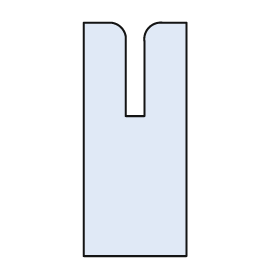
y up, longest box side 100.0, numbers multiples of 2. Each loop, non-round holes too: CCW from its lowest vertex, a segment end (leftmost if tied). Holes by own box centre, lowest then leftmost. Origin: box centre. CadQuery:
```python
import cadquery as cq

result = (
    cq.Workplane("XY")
    .moveTo(-22.0, -50.0)
    .lineTo(22.0, -50.0)
    .lineTo(22.0, 50.0)
    .lineTo(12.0, 50.0)
    .threePointArc((6.0, 48.0), (4.0, 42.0))
    .lineTo(4.0, 10.0)
    .lineTo(-4.0, 10.0)
    .lineTo(-4.0, 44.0)
    .threePointArc((-6.0, 48.0), (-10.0, 50.0))
    .lineTo(-22.0, 50.0)
    .close()
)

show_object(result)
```